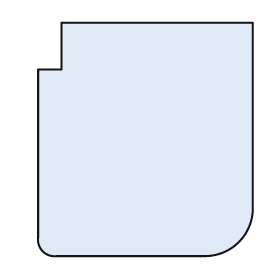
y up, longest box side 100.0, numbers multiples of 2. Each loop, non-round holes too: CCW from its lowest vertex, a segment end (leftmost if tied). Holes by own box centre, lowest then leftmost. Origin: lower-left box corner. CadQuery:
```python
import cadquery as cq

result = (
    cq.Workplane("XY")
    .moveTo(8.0, 0.0)
    .lineTo(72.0, 0.0)
    .threePointArc((86.0, 6.0), (92.0, 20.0))
    .lineTo(92.0, 100.0)
    .lineTo(10.0, 100.0)
    .lineTo(10.0, 80.0)
    .lineTo(0.0, 80.0)
    .lineTo(0.0, 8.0)
    .threePointArc((2.0, 2.0), (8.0, 0.0))
    .close()
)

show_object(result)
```